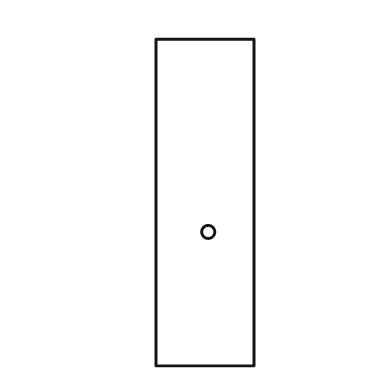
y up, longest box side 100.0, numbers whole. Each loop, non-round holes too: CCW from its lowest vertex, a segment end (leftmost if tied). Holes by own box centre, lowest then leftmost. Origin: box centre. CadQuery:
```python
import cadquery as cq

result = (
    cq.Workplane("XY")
    .moveTo(-15.0, -50.0)
    .lineTo(15.0, -50.0)
    .lineTo(15.0, 50.0)
    .lineTo(-15.0, 50.0)
    .close()
    .moveTo(1.0, -9.0)
    .circle(2.0)
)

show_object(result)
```